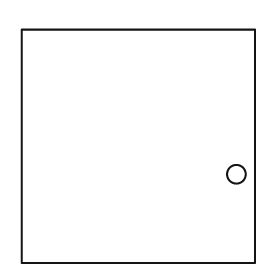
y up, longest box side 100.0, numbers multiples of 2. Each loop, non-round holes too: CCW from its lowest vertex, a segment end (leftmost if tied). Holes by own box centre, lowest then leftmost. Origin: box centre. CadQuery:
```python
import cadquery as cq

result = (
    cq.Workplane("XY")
    .moveTo(-50.0, -50.0)
    .lineTo(50.0, -50.0)
    .lineTo(50.0, 50.0)
    .lineTo(-50.0, 50.0)
    .close()
    .moveTo(42.0, -12.0)
    .circle(4.0)
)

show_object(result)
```